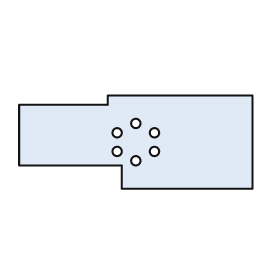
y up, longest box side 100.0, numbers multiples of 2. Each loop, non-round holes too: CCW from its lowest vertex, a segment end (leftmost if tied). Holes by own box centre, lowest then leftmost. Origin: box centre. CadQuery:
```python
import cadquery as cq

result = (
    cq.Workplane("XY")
    .moveTo(-6.0, -20.0)
    .lineTo(50.0, -20.0)
    .lineTo(50.0, 20.0)
    .lineTo(-12.0, 20.0)
    .lineTo(-12.0, 16.0)
    .lineTo(-50.0, 16.0)
    .lineTo(-50.0, -10.0)
    .lineTo(-6.0, -10.0)
    .close()
    .moveTo(0.0, -8.0)
    .circle(2.0)
    .moveTo(-8.0, -4.0)
    .circle(2.0)
    .moveTo(8.0, -4.0)
    .circle(2.0)
    .moveTo(-8.0, 4.0)
    .circle(2.0)
    .moveTo(8.0, 4.0)
    .circle(2.0)
    .moveTo(0.0, 8.0)
    .circle(2.0)
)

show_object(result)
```